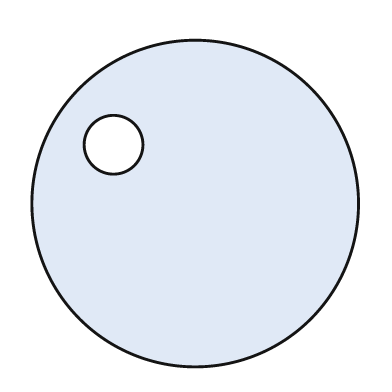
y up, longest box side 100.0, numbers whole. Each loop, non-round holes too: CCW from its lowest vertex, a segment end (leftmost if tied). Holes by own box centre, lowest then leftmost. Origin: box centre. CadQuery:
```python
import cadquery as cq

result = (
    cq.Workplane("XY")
    .moveTo(0.0, 0.0)
    .circle(50.0)
    .moveTo(-25.0, 18.0)
    .circle(9.0)
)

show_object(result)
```